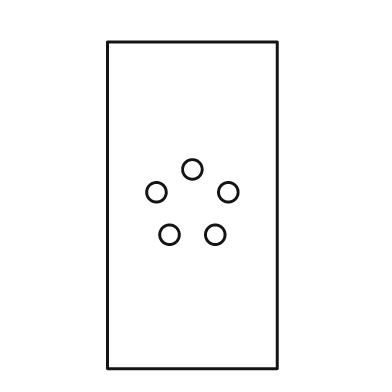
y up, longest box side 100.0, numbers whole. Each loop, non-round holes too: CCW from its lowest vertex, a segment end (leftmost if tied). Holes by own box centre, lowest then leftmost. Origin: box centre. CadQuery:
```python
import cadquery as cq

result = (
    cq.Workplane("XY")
    .moveTo(-26.0, -50.0)
    .lineTo(26.0, -50.0)
    .lineTo(26.0, 50.0)
    .lineTo(-26.0, 50.0)
    .close()
    .moveTo(-7.0, -9.0)
    .circle(3.0)
    .moveTo(7.0, -9.0)
    .circle(3.0)
    .moveTo(-11.0, 4.0)
    .circle(3.0)
    .moveTo(11.0, 4.0)
    .circle(3.0)
    .moveTo(0.0, 11.0)
    .circle(3.0)
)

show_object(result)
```